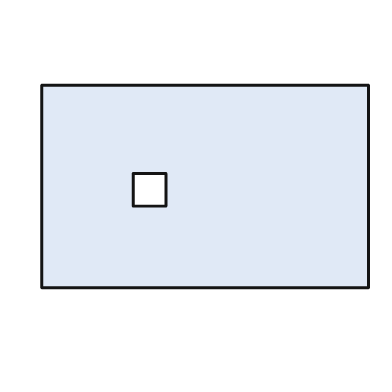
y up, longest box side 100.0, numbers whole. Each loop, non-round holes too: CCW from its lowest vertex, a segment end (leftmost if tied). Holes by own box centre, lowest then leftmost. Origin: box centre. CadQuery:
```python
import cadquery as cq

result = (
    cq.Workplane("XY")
    .moveTo(-50.0, -31.0)
    .lineTo(50.0, -31.0)
    .lineTo(50.0, 31.0)
    .lineTo(-50.0, 31.0)
    .close()
    .moveTo(-22.0, -6.0)
    .lineTo(-12.0, -6.0)
    .lineTo(-12.0, 4.0)
    .lineTo(-22.0, 4.0)
    .close()
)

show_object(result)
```